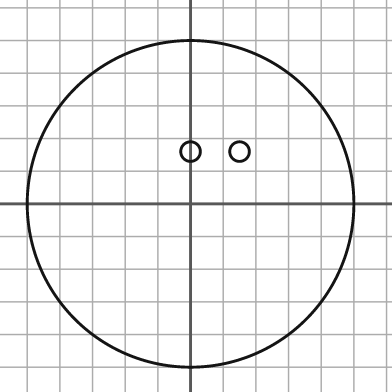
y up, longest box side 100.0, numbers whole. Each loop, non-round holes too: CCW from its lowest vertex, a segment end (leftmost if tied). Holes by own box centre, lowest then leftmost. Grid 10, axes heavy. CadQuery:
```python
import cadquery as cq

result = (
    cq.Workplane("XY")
    .moveTo(0.0, 0.0)
    .circle(50.0)
    .moveTo(0.0, 16.0)
    .circle(3.0)
    .moveTo(15.0, 16.0)
    .circle(3.0)
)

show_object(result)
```